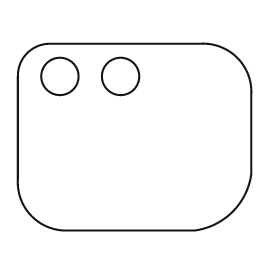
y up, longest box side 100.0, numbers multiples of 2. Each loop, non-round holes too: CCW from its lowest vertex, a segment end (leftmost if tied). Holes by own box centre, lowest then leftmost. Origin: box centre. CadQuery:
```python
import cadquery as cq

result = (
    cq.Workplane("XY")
    .moveTo(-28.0, -40.0)
    .lineTo(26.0, -40.0)
    .threePointArc((42.0, -32.0), (50.0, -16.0))
    .lineTo(50.0, 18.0)
    .threePointArc((44.0, 34.0), (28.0, 40.0))
    .lineTo(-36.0, 40.0)
    .threePointArc((-46.0, 36.0), (-50.0, 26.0))
    .lineTo(-50.0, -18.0)
    .threePointArc((-44.0, -34.0), (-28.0, -40.0))
    .close()
    .moveTo(-32.0, 26.0)
    .circle(8.0)
    .moveTo(-6.0, 26.0)
    .circle(8.0)
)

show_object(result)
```